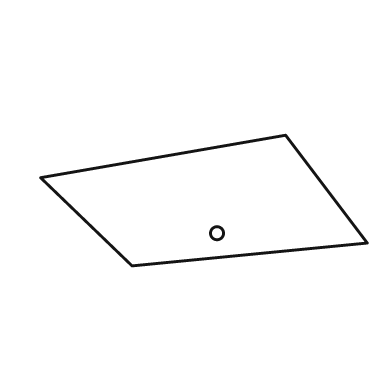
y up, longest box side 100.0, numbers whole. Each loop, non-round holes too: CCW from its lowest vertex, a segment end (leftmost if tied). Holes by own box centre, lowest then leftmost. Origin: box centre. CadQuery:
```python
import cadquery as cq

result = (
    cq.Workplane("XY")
    .moveTo(-22.0, -20.0)
    .lineTo(50.0, -13.0)
    .lineTo(25.0, 20.0)
    .lineTo(-50.0, 7.0)
    .close()
    .moveTo(4.0, -10.0)
    .circle(2.0)
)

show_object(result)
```